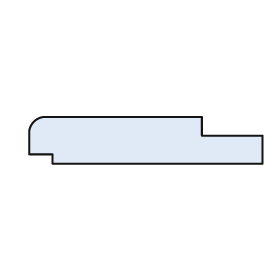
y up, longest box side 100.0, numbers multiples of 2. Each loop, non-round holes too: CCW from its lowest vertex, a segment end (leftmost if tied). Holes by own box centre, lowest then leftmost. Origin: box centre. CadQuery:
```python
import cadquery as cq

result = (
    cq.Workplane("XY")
    .moveTo(-40.0, -10.0)
    .lineTo(50.0, -10.0)
    .lineTo(50.0, 2.0)
    .lineTo(24.0, 2.0)
    .lineTo(24.0, 10.0)
    .lineTo(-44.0, 10.0)
    .threePointArc((-48.0, 8.0), (-50.0, 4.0))
    .lineTo(-50.0, -6.0)
    .lineTo(-40.0, -6.0)
    .close()
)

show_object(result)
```